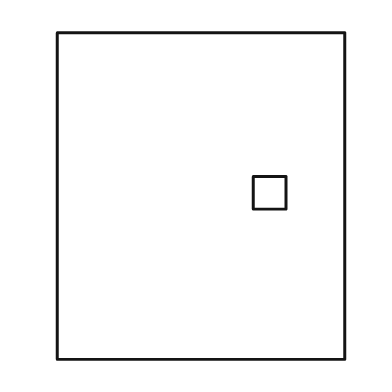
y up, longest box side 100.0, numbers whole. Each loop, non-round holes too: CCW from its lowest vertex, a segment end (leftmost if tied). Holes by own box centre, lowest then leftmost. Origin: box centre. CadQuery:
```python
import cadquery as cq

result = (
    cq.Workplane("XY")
    .moveTo(-44.0, -50.0)
    .lineTo(44.0, -50.0)
    .lineTo(44.0, 50.0)
    .lineTo(-44.0, 50.0)
    .close()
    .moveTo(16.0, -4.0)
    .lineTo(26.0, -4.0)
    .lineTo(26.0, 6.0)
    .lineTo(16.0, 6.0)
    .close()
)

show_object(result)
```